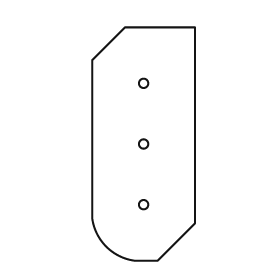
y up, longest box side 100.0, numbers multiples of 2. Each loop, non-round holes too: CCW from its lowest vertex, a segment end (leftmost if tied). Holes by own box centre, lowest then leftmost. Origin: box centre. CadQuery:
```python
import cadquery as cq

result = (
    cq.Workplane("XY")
    .moveTo(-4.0, -50.0)
    .lineTo(6.0, -50.0)
    .lineTo(22.0, -34.0)
    .lineTo(22.0, 50.0)
    .lineTo(-8.0, 50.0)
    .lineTo(-22.0, 36.0)
    .lineTo(-22.0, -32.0)
    .threePointArc((-16.0, -44.0), (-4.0, -50.0))
    .close()
    .moveTo(0.0, -26.0)
    .circle(2.0)
    .moveTo(0.0, 0.0)
    .circle(2.0)
    .moveTo(0.0, 26.0)
    .circle(2.0)
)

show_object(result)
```